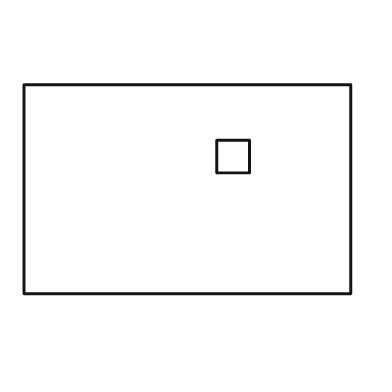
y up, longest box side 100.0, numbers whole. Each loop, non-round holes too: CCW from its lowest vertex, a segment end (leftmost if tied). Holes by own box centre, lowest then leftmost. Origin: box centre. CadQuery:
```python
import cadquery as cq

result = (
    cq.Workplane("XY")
    .moveTo(-50.0, -32.0)
    .lineTo(50.0, -32.0)
    .lineTo(50.0, 32.0)
    .lineTo(-50.0, 32.0)
    .close()
    .moveTo(9.0, 5.0)
    .lineTo(19.0, 5.0)
    .lineTo(19.0, 15.0)
    .lineTo(9.0, 15.0)
    .close()
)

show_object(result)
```